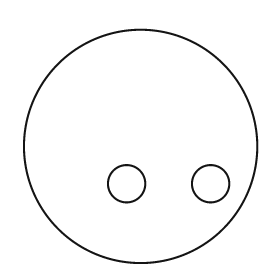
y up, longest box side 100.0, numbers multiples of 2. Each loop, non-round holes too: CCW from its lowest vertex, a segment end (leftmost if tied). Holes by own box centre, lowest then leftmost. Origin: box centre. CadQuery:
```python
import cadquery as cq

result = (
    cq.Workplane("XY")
    .moveTo(0.0, 0.0)
    .circle(50.0)
    .moveTo(-6.0, -16.0)
    .circle(8.0)
    .moveTo(30.0, -16.0)
    .circle(8.0)
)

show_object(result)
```